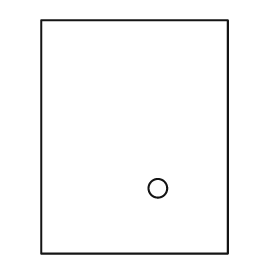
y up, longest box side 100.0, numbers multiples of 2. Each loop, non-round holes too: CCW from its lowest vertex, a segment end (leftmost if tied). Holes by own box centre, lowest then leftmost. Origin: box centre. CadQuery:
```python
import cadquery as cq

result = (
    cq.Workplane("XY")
    .moveTo(-40.0, -50.0)
    .lineTo(40.0, -50.0)
    .lineTo(40.0, 50.0)
    .lineTo(-40.0, 50.0)
    .close()
    .moveTo(10.0, -22.0)
    .circle(4.0)
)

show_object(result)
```